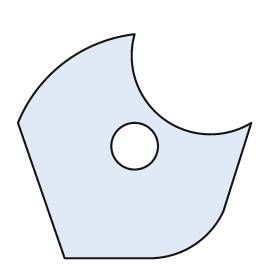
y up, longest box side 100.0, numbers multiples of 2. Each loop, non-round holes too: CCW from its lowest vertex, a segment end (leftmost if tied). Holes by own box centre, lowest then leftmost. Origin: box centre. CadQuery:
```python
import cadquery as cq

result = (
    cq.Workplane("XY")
    .moveTo(-30.0, -48.0)
    .lineTo(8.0, -48.0)
    .threePointArc((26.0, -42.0), (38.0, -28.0))
    .lineTo(50.0, 10.0)
    .threePointArc((12.0, 12.0), (0.0, 48.0))
    .threePointArc((-30.0, 36.0), (-50.0, 10.0))
    .close()
    .moveTo(0.0, 0.0)
    .circle(10.0)
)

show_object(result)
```